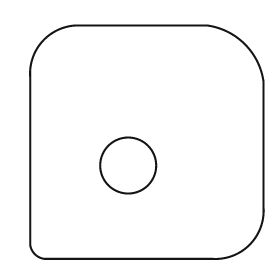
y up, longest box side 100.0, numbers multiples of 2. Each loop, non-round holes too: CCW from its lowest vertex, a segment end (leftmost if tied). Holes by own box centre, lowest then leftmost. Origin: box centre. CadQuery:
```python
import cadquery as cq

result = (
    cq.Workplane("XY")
    .moveTo(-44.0, -50.0)
    .lineTo(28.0, -50.0)
    .threePointArc((44.0, -44.0), (50.0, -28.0))
    .lineTo(50.0, 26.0)
    .threePointArc((42.0, 42.0), (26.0, 50.0))
    .lineTo(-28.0, 50.0)
    .threePointArc((-44.0, 44.0), (-50.0, 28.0))
    .lineTo(-50.0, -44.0)
    .threePointArc((-48.0, -48.0), (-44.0, -50.0))
    .close()
    .moveTo(-8.0, -10.0)
    .circle(12.0)
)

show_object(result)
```